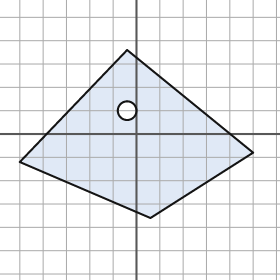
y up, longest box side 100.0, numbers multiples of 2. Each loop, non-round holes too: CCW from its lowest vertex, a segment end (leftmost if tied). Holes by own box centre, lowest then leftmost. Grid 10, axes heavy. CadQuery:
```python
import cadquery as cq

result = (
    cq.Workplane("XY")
    .moveTo(6.0, -36.0)
    .lineTo(50.0, -8.0)
    .lineTo(-4.0, 36.0)
    .lineTo(-50.0, -12.0)
    .close()
    .moveTo(-4.0, 10.0)
    .circle(4.0)
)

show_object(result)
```